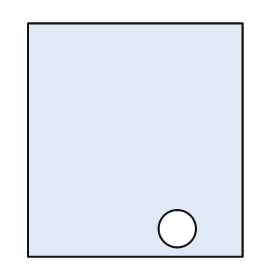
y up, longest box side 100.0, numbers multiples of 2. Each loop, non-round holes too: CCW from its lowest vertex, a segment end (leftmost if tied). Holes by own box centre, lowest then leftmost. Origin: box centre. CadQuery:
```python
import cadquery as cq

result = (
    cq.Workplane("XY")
    .moveTo(-46.0, -50.0)
    .lineTo(46.0, -50.0)
    .lineTo(46.0, 50.0)
    .lineTo(-46.0, 50.0)
    .close()
    .moveTo(18.0, -38.0)
    .circle(8.0)
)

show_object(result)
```